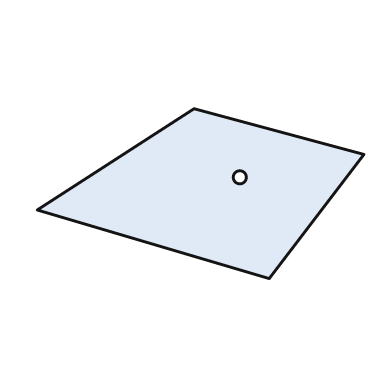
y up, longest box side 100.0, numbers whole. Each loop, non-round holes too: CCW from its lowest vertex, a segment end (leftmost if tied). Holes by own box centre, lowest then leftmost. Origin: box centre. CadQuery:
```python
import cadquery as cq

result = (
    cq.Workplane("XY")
    .moveTo(21.0, -26.0)
    .lineTo(50.0, 12.0)
    .lineTo(-2.0, 26.0)
    .lineTo(-50.0, -5.0)
    .close()
    .moveTo(12.0, 5.0)
    .circle(2.0)
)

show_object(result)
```